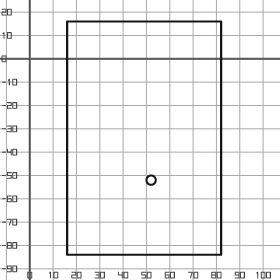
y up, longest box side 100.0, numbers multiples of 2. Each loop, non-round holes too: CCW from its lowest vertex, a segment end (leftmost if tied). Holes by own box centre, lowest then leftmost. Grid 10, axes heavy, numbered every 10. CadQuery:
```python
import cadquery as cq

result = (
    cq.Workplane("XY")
    .moveTo(16.0, -84.0)
    .lineTo(82.0, -84.0)
    .lineTo(82.0, 16.0)
    .lineTo(16.0, 16.0)
    .close()
    .moveTo(52.0, -52.0)
    .circle(2.0)
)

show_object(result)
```